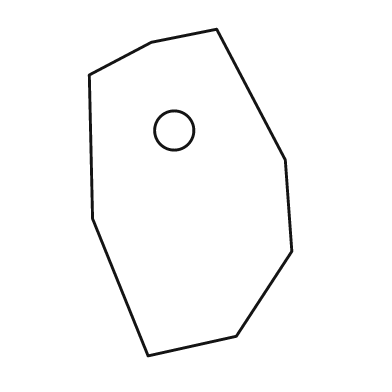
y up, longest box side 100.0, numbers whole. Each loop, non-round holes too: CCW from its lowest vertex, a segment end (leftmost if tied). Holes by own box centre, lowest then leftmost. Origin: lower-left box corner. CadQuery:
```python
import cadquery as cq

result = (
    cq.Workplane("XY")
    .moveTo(18.0, 0.0)
    .lineTo(45.0, 6.0)
    .lineTo(62.0, 32.0)
    .lineTo(60.0, 60.0)
    .lineTo(39.0, 100.0)
    .lineTo(19.0, 96.0)
    .lineTo(0.0, 86.0)
    .lineTo(1.0, 42.0)
    .close()
    .moveTo(26.0, 69.0)
    .circle(6.0)
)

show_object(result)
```